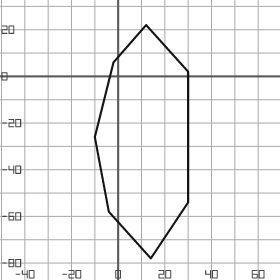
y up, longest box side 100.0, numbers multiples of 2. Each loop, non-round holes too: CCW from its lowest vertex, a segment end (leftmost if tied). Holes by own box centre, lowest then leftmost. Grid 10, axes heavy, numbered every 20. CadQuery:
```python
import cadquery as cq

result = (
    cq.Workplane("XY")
    .moveTo(14.0, -78.0)
    .lineTo(30.0, -54.0)
    .lineTo(30.0, 2.0)
    .lineTo(12.0, 22.0)
    .lineTo(-2.0, 6.0)
    .lineTo(-10.0, -26.0)
    .lineTo(-4.0, -58.0)
    .close()
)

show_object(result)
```